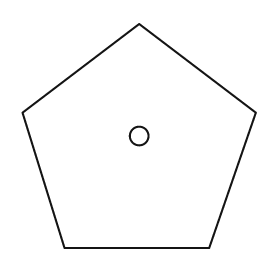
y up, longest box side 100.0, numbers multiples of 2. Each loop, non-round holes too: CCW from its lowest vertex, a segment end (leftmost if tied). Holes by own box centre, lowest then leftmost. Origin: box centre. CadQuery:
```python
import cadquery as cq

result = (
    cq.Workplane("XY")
    .moveTo(-32.0, -48.0)
    .lineTo(30.0, -48.0)
    .lineTo(50.0, 10.0)
    .lineTo(0.0, 48.0)
    .lineTo(-50.0, 10.0)
    .close()
    .moveTo(0.0, 0.0)
    .circle(4.0)
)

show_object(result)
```